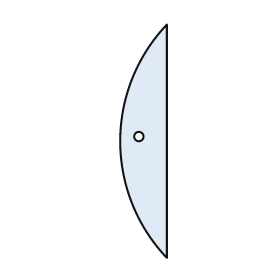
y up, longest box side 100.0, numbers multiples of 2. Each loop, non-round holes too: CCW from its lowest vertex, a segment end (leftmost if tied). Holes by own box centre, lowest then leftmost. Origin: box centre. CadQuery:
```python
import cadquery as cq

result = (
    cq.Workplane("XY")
    .moveTo(10.0, -50.0)
    .lineTo(10.0, 50.0)
    .threePointArc((-10.0, 0.0), (10.0, -50.0))
    .close()
    .moveTo(-2.0, 2.0)
    .circle(2.0)
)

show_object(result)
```